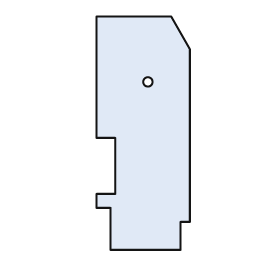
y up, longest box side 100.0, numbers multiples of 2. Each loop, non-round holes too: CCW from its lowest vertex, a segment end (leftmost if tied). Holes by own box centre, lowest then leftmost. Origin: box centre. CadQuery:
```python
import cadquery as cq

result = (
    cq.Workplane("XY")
    .moveTo(-14.0, -50.0)
    .lineTo(16.0, -50.0)
    .lineTo(16.0, -38.0)
    .lineTo(20.0, -38.0)
    .lineTo(20.0, 36.0)
    .lineTo(12.0, 50.0)
    .lineTo(-20.0, 50.0)
    .lineTo(-20.0, -2.0)
    .lineTo(-12.0, -2.0)
    .lineTo(-12.0, -26.0)
    .lineTo(-20.0, -26.0)
    .lineTo(-20.0, -32.0)
    .lineTo(-14.0, -32.0)
    .close()
    .moveTo(2.0, 22.0)
    .circle(2.0)
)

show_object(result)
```